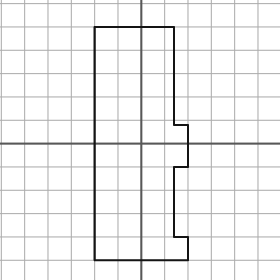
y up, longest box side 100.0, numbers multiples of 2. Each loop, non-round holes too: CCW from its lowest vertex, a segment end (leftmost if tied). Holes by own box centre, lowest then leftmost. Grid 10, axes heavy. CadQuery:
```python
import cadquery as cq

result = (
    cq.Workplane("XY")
    .moveTo(-20.0, -50.0)
    .lineTo(20.0, -50.0)
    .lineTo(20.0, -40.0)
    .lineTo(14.0, -40.0)
    .lineTo(14.0, -10.0)
    .lineTo(20.0, -10.0)
    .lineTo(20.0, 8.0)
    .lineTo(14.0, 8.0)
    .lineTo(14.0, 50.0)
    .lineTo(-20.0, 50.0)
    .close()
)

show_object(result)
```